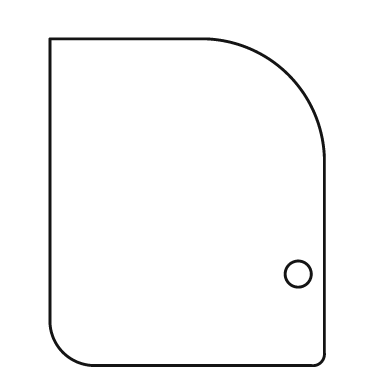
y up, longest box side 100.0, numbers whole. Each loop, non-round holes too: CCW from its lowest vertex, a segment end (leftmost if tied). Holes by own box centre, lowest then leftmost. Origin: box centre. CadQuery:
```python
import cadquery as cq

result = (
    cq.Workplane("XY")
    .moveTo(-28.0, -50.0)
    .lineTo(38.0, -50.0)
    .threePointArc((41.0, -49.0), (42.0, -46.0))
    .lineTo(42.0, 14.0)
    .threePointArc((31.0, 39.0), (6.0, 50.0))
    .lineTo(-42.0, 50.0)
    .lineTo(-42.0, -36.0)
    .threePointArc((-38.0, -46.0), (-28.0, -50.0))
    .close()
    .moveTo(34.0, -22.0)
    .circle(4.0)
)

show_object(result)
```